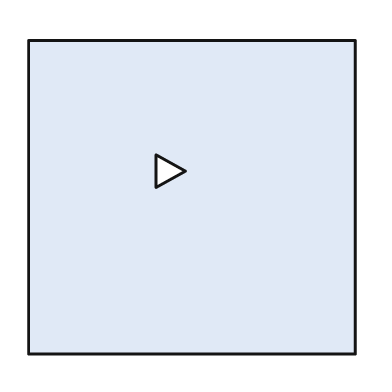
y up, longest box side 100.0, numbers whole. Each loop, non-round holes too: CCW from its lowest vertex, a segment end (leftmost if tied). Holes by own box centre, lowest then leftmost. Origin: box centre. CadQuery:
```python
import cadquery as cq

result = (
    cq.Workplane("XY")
    .moveTo(-50.0, -48.0)
    .lineTo(50.0, -48.0)
    .lineTo(50.0, 48.0)
    .lineTo(-50.0, 48.0)
    .close()
    .moveTo(-11.0, 3.0)
    .lineTo(-2.0, 8.0)
    .lineTo(-11.0, 13.0)
    .close()
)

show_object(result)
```